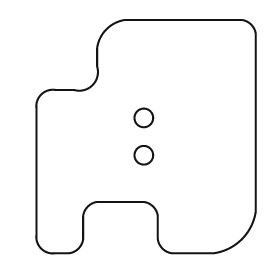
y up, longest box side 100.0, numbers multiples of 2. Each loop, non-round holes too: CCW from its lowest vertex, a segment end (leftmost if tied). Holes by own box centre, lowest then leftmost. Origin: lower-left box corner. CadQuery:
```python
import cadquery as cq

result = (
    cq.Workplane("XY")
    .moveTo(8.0, 0.0)
    .lineTo(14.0, 0.0)
    .threePointArc((18.0, 2.0), (20.0, 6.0))
    .lineTo(20.0, 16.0)
    .threePointArc((22.0, 20.0), (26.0, 22.0))
    .lineTo(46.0, 22.0)
    .threePointArc((50.0, 20.0), (52.0, 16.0))
    .lineTo(52.0, 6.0)
    .threePointArc((54.0, 2.0), (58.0, 0.0))
    .lineTo(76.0, 0.0)
    .threePointArc((88.0, 6.0), (94.0, 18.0))
    .lineTo(94.0, 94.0)
    .threePointArc((92.0, 98.0), (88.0, 100.0))
    .lineTo(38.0, 100.0)
    .threePointArc((30.0, 96.0), (26.0, 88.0))
    .lineTo(26.0, 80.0)
    .threePointArc((24.0, 72.0), (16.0, 70.0))
    .lineTo(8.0, 70.0)
    .threePointArc((2.0, 68.0), (0.0, 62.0))
    .lineTo(0.0, 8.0)
    .threePointArc((2.0, 2.0), (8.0, 0.0))
    .close()
    .moveTo(46.0, 42.0)
    .circle(4.0)
    .moveTo(46.0, 58.0)
    .circle(4.0)
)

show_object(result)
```